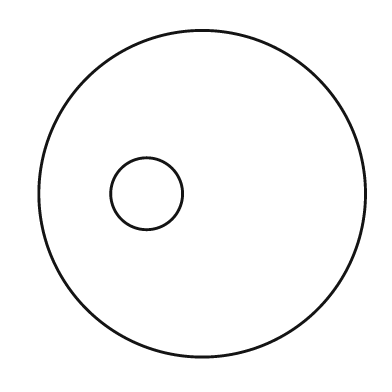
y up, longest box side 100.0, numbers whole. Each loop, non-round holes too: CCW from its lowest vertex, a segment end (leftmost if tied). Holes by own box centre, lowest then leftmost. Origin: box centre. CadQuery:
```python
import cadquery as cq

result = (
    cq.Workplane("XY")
    .moveTo(0.0, 0.0)
    .circle(50.0)
    .moveTo(-17.0, 0.0)
    .circle(11.0)
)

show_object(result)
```